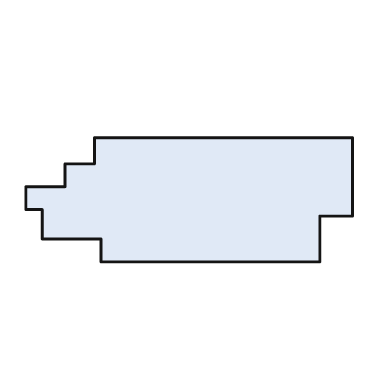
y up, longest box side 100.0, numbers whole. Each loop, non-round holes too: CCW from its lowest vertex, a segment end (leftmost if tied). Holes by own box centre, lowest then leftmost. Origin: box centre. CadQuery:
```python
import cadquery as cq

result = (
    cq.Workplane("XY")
    .moveTo(-27.0, -19.0)
    .lineTo(40.0, -19.0)
    .lineTo(40.0, -5.0)
    .lineTo(50.0, -5.0)
    .lineTo(50.0, 19.0)
    .lineTo(-29.0, 19.0)
    .lineTo(-29.0, 11.0)
    .lineTo(-38.0, 11.0)
    .lineTo(-38.0, 4.0)
    .lineTo(-50.0, 4.0)
    .lineTo(-50.0, -3.0)
    .lineTo(-45.0, -3.0)
    .lineTo(-45.0, -12.0)
    .lineTo(-27.0, -12.0)
    .close()
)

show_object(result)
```